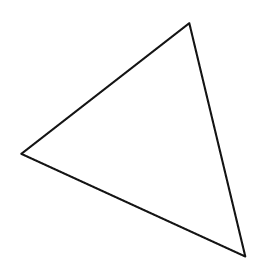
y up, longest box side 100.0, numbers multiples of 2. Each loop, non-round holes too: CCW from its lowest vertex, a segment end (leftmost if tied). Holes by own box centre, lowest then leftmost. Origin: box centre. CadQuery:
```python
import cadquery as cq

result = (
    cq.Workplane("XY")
    .moveTo(48.0, -50.0)
    .lineTo(24.0, 50.0)
    .lineTo(-48.0, -6.0)
    .close()
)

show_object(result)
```